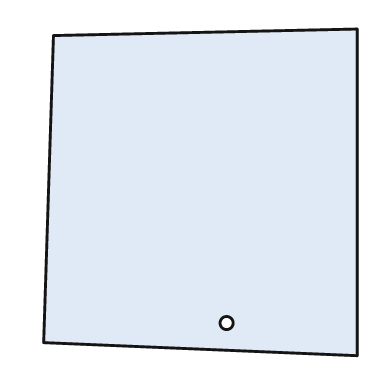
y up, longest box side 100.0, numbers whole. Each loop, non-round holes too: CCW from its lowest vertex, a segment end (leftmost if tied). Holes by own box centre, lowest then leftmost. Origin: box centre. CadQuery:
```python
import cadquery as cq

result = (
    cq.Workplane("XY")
    .moveTo(48.0, -50.0)
    .lineTo(48.0, 50.0)
    .lineTo(-45.0, 48.0)
    .lineTo(-48.0, -46.0)
    .close()
    .moveTo(8.0, -40.0)
    .circle(2.0)
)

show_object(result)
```